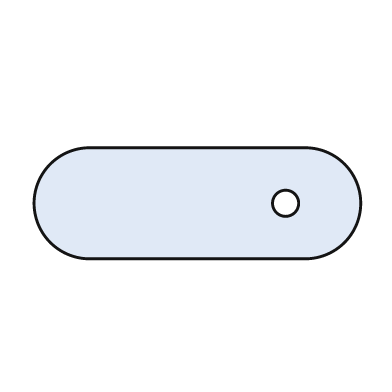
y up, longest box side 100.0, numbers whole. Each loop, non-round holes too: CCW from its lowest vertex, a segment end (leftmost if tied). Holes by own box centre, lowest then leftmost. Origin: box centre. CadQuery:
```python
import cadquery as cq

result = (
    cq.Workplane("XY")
    .moveTo(-33.0, -17.0)
    .lineTo(33.0, -17.0)
    .threePointArc((50.0, 0.0), (33.0, 17.0))
    .lineTo(-33.0, 17.0)
    .threePointArc((-50.0, 0.0), (-33.0, -17.0))
    .close()
    .moveTo(27.0, 0.0)
    .circle(4.0)
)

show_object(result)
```